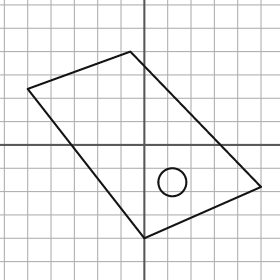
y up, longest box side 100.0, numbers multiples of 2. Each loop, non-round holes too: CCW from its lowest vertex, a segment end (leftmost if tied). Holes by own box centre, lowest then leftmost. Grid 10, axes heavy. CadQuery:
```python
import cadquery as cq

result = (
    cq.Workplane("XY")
    .moveTo(0.0, -40.0)
    .lineTo(50.0, -18.0)
    .lineTo(-6.0, 40.0)
    .lineTo(-50.0, 24.0)
    .close()
    .moveTo(12.0, -16.0)
    .circle(6.0)
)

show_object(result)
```